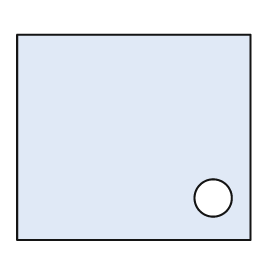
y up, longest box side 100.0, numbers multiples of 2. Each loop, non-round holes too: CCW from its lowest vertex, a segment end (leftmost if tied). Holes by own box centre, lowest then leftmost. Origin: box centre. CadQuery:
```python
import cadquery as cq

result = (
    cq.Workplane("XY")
    .moveTo(-50.0, -44.0)
    .lineTo(50.0, -44.0)
    .lineTo(50.0, 44.0)
    .lineTo(-50.0, 44.0)
    .close()
    .moveTo(34.0, -26.0)
    .circle(8.0)
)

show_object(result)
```